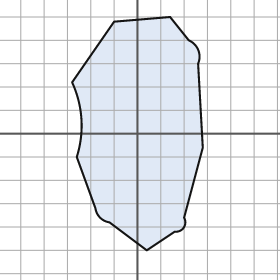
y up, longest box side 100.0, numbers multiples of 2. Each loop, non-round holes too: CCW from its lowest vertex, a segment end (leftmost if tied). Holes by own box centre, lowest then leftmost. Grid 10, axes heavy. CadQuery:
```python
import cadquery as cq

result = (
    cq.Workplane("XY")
    .moveTo(4.0, -50.0)
    .lineTo(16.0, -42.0)
    .threePointArc((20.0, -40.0), (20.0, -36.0))
    .lineTo(28.0, -6.0)
    .lineTo(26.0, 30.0)
    .threePointArc((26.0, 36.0), (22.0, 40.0))
    .lineTo(14.0, 50.0)
    .lineTo(-10.0, 48.0)
    .lineTo(-28.0, 22.0)
    .threePointArc((-24.0, 6.0), (-26.0, -10.0))
    .lineTo(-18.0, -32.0)
    .threePointArc((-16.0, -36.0), (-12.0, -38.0))
    .close()
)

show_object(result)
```